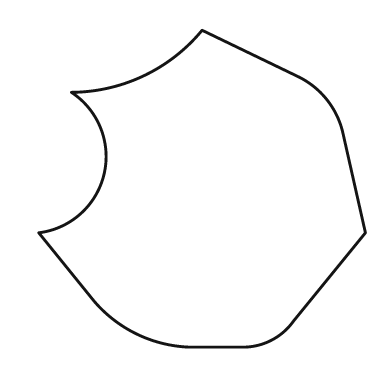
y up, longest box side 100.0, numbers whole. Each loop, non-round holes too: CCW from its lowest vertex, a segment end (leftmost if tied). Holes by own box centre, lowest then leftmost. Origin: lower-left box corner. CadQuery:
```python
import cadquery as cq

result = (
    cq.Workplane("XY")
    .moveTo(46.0, 0.0)
    .lineTo(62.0, 0.0)
    .threePointArc((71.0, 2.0), (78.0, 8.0))
    .lineTo(100.0, 35.0)
    .lineTo(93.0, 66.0)
    .threePointArc((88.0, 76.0), (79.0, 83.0))
    .lineTo(50.0, 97.0)
    .threePointArc((32.0, 83.0), (10.0, 78.0))
    .threePointArc((20.0, 53.0), (0.0, 35.0))
    .lineTo(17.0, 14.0)
    .threePointArc((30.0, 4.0), (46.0, 0.0))
    .close()
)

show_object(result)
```